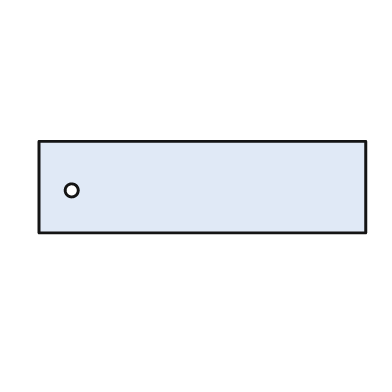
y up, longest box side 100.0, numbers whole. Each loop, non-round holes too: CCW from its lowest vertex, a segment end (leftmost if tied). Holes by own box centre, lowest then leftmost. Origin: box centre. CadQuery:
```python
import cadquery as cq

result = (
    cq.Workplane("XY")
    .moveTo(-50.0, -14.0)
    .lineTo(50.0, -14.0)
    .lineTo(50.0, 14.0)
    .lineTo(-50.0, 14.0)
    .close()
    .moveTo(-40.0, -1.0)
    .circle(2.0)
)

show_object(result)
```